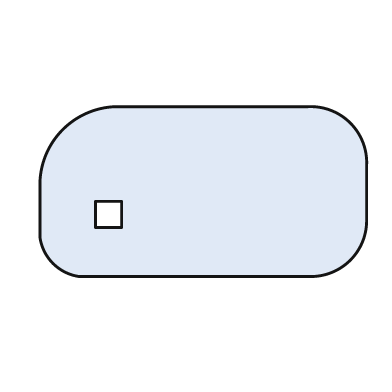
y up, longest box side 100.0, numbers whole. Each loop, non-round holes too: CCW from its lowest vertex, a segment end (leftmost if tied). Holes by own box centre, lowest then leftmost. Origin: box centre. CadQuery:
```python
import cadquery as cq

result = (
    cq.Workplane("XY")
    .moveTo(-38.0, -26.0)
    .lineTo(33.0, -26.0)
    .threePointArc((45.0, -21.0), (50.0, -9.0))
    .lineTo(50.0, 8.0)
    .threePointArc((45.0, 21.0), (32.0, 26.0))
    .lineTo(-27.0, 26.0)
    .threePointArc((-43.0, 19.0), (-50.0, 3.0))
    .lineTo(-50.0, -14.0)
    .threePointArc((-46.0, -22.0), (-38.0, -26.0))
    .close()
    .moveTo(-33.0, -11.0)
    .lineTo(-25.0, -11.0)
    .lineTo(-25.0, -3.0)
    .lineTo(-33.0, -3.0)
    .close()
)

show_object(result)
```